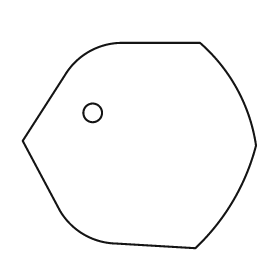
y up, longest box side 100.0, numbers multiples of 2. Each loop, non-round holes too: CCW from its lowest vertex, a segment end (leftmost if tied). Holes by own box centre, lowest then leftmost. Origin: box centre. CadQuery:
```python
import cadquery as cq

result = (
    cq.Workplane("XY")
    .moveTo(24.0, -44.0)
    .threePointArc((40.0, -24.0), (50.0, 0.0))
    .threePointArc((42.0, 24.0), (26.0, 44.0))
    .lineTo(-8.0, 44.0)
    .threePointArc((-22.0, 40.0), (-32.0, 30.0))
    .lineTo(-50.0, 2.0)
    .lineTo(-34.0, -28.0)
    .threePointArc((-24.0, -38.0), (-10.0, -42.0))
    .close()
    .moveTo(-20.0, 14.0)
    .circle(4.0)
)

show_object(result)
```